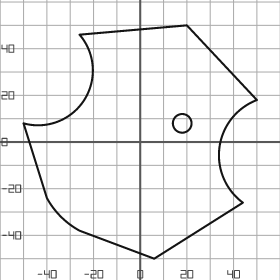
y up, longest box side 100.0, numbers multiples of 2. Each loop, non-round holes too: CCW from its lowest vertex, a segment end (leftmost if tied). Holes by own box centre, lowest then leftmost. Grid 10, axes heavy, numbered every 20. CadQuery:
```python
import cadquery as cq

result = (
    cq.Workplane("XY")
    .moveTo(6.0, -50.0)
    .lineTo(44.0, -26.0)
    .threePointArc((34.0, -2.0), (50.0, 18.0))
    .lineTo(20.0, 50.0)
    .lineTo(-26.0, 46.0)
    .threePointArc((-24.0, 18.0), (-50.0, 8.0))
    .lineTo(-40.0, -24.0)
    .threePointArc((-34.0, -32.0), (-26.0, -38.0))
    .close()
    .moveTo(18.0, 8.0)
    .circle(4.0)
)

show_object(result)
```